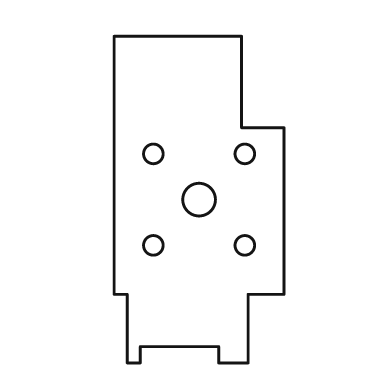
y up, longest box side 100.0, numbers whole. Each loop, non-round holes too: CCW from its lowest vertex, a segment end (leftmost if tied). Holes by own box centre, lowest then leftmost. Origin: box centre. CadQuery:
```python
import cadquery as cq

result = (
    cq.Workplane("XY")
    .moveTo(-22.0, -50.0)
    .lineTo(-18.0, -50.0)
    .lineTo(-18.0, -45.0)
    .lineTo(6.0, -45.0)
    .lineTo(6.0, -50.0)
    .lineTo(15.0, -50.0)
    .lineTo(15.0, -29.0)
    .lineTo(26.0, -29.0)
    .lineTo(26.0, 22.0)
    .lineTo(13.0, 22.0)
    .lineTo(13.0, 50.0)
    .lineTo(-26.0, 50.0)
    .lineTo(-26.0, -29.0)
    .lineTo(-22.0, -29.0)
    .close()
    .moveTo(-14.0, -14.0)
    .circle(3.0)
    .moveTo(14.0, -14.0)
    .circle(3.0)
    .moveTo(0.0, 0.0)
    .circle(5.0)
    .moveTo(-14.0, 14.0)
    .circle(3.0)
    .moveTo(14.0, 14.0)
    .circle(3.0)
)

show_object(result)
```